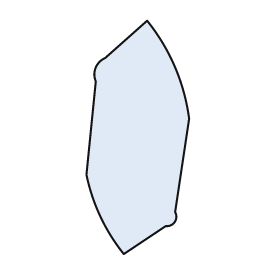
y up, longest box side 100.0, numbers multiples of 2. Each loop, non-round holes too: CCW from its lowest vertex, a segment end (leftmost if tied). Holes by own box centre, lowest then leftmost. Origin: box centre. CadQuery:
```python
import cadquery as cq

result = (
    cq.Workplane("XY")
    .moveTo(-6.0, -50.0)
    .lineTo(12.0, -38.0)
    .threePointArc((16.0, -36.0), (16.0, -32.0))
    .lineTo(22.0, 8.0)
    .threePointArc((16.0, 30.0), (4.0, 50.0))
    .lineTo(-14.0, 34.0)
    .threePointArc((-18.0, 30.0), (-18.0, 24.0))
    .lineTo(-22.0, -16.0)
    .threePointArc((-16.0, -34.0), (-6.0, -50.0))
    .close()
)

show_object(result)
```